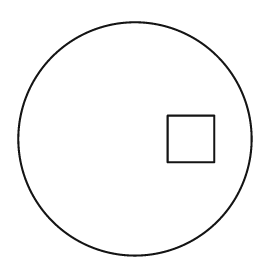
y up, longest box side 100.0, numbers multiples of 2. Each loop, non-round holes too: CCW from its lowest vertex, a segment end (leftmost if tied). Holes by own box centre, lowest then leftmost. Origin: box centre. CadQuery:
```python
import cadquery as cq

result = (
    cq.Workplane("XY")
    .moveTo(0.0, 0.0)
    .circle(50.0)
    .moveTo(14.0, -10.0)
    .lineTo(34.0, -10.0)
    .lineTo(34.0, 10.0)
    .lineTo(14.0, 10.0)
    .close()
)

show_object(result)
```